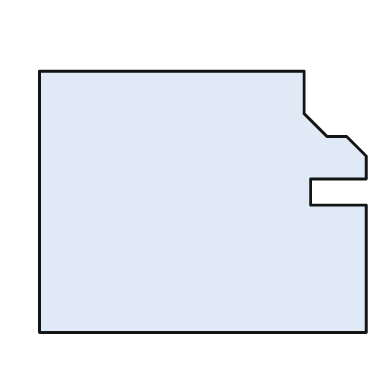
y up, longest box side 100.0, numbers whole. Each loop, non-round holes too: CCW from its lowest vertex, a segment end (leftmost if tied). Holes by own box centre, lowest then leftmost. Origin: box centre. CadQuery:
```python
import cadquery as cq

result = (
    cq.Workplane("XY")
    .moveTo(-50.0, -40.0)
    .lineTo(50.0, -40.0)
    .lineTo(50.0, -1.0)
    .lineTo(33.0, -1.0)
    .lineTo(33.0, 7.0)
    .lineTo(50.0, 7.0)
    .lineTo(50.0, 14.0)
    .lineTo(44.0, 20.0)
    .lineTo(38.0, 20.0)
    .lineTo(31.0, 27.0)
    .lineTo(31.0, 40.0)
    .lineTo(-50.0, 40.0)
    .close()
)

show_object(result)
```